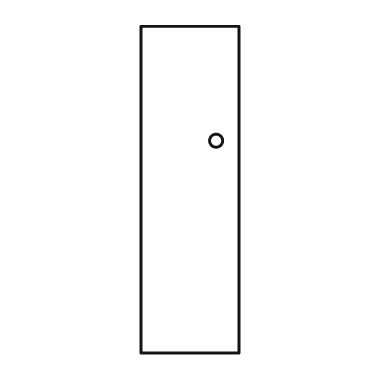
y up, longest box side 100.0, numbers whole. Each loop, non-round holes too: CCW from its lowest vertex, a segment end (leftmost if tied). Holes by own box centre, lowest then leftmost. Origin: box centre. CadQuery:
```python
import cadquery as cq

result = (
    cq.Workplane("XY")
    .moveTo(-15.0, -50.0)
    .lineTo(15.0, -50.0)
    .lineTo(15.0, 50.0)
    .lineTo(-15.0, 50.0)
    .close()
    .moveTo(8.0, 15.0)
    .circle(2.0)
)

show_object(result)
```